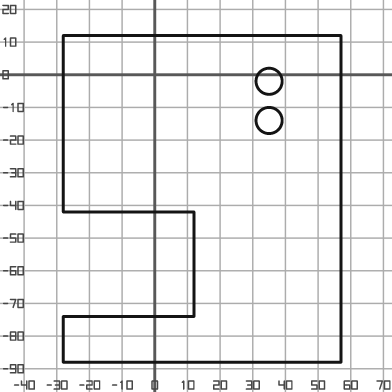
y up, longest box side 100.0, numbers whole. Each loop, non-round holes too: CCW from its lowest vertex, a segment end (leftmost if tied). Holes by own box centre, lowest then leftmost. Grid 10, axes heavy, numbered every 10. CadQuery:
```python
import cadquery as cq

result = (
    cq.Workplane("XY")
    .moveTo(-28.0, -88.0)
    .lineTo(57.0, -88.0)
    .lineTo(57.0, 12.0)
    .lineTo(-28.0, 12.0)
    .lineTo(-28.0, -42.0)
    .lineTo(12.0, -42.0)
    .lineTo(12.0, -74.0)
    .lineTo(-28.0, -74.0)
    .close()
    .moveTo(35.0, -14.0)
    .circle(4.0)
    .moveTo(35.0, -2.0)
    .circle(4.0)
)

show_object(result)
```